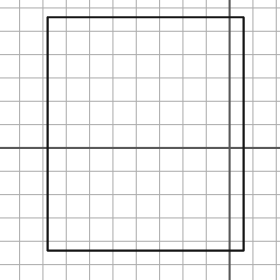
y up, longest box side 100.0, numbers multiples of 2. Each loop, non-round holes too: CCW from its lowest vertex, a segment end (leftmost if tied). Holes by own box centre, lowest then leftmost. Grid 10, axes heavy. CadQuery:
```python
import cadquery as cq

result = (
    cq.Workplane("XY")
    .moveTo(-78.0, -44.0)
    .lineTo(6.0, -44.0)
    .lineTo(6.0, 56.0)
    .lineTo(-78.0, 56.0)
    .close()
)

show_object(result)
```